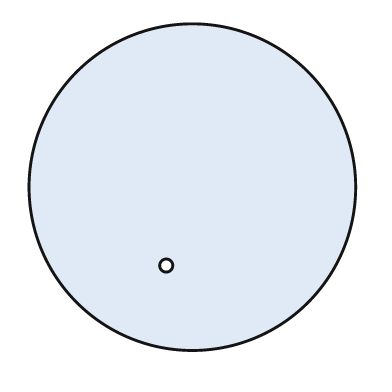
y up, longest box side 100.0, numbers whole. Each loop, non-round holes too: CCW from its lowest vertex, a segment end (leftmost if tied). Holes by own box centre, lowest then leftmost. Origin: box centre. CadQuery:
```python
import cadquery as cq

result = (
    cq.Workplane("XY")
    .moveTo(0.0, 0.0)
    .circle(50.0)
    .moveTo(-8.0, -24.0)
    .circle(2.0)
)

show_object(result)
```